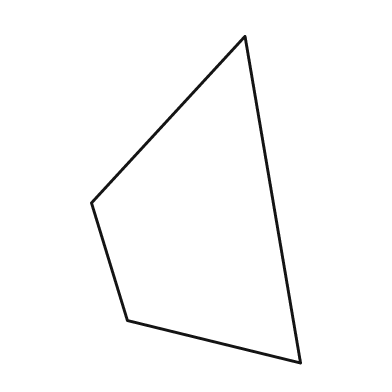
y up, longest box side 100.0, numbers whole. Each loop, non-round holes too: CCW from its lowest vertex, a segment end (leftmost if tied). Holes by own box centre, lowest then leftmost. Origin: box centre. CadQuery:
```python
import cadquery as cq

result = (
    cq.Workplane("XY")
    .moveTo(32.0, -50.0)
    .lineTo(15.0, 50.0)
    .lineTo(-32.0, -1.0)
    .lineTo(-21.0, -37.0)
    .close()
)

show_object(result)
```